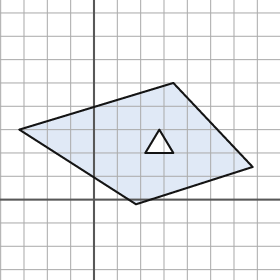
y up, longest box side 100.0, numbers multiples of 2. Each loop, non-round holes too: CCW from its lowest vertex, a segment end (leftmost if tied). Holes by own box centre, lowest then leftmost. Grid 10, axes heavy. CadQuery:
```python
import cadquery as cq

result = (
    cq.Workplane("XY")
    .moveTo(18.0, -2.0)
    .lineTo(68.0, 14.0)
    .lineTo(34.0, 50.0)
    .lineTo(-32.0, 30.0)
    .close()
    .moveTo(22.0, 20.0)
    .lineTo(34.0, 20.0)
    .lineTo(28.0, 30.0)
    .close()
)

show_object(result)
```